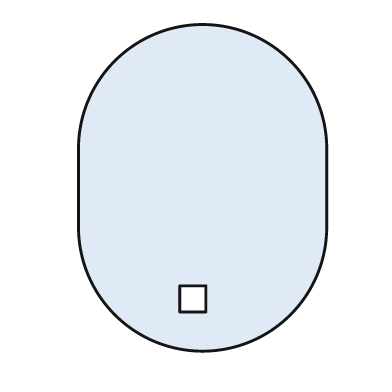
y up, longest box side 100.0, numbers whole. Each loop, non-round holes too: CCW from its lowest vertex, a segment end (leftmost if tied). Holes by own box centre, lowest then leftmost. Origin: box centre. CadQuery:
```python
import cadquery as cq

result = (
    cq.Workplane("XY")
    .moveTo(-38.0, -12.0)
    .threePointArc((0.0, -50.0), (38.0, -12.0))
    .lineTo(38.0, 12.0)
    .threePointArc((0.0, 50.0), (-38.0, 12.0))
    .close()
    .moveTo(-7.0, -38.0)
    .lineTo(1.0, -38.0)
    .lineTo(1.0, -30.0)
    .lineTo(-7.0, -30.0)
    .close()
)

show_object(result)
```